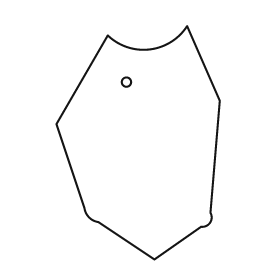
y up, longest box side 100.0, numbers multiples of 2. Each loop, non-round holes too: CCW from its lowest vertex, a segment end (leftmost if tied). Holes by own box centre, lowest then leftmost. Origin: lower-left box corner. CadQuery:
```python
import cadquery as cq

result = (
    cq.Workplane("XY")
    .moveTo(42.0, 0.0)
    .lineTo(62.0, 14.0)
    .threePointArc((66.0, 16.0), (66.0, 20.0))
    .lineTo(70.0, 68.0)
    .lineTo(56.0, 100.0)
    .threePointArc((40.0, 90.0), (22.0, 96.0))
    .lineTo(0.0, 58.0)
    .lineTo(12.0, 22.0)
    .threePointArc((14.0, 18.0), (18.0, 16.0))
    .close()
    .moveTo(30.0, 76.0)
    .circle(2.0)
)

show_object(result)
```